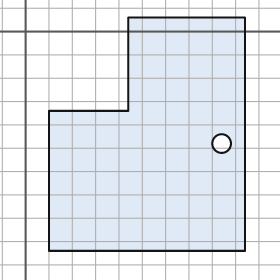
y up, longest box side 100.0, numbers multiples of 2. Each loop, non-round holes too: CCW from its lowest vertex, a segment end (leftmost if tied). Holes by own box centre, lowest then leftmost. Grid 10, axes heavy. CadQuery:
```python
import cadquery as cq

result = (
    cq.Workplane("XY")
    .moveTo(10.0, -94.0)
    .lineTo(94.0, -94.0)
    .lineTo(94.0, 6.0)
    .lineTo(44.0, 6.0)
    .lineTo(44.0, -34.0)
    .lineTo(10.0, -34.0)
    .close()
    .moveTo(84.0, -48.0)
    .circle(4.0)
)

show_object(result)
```